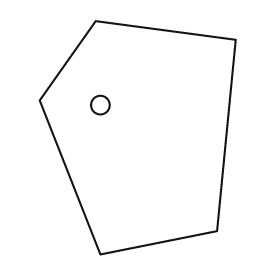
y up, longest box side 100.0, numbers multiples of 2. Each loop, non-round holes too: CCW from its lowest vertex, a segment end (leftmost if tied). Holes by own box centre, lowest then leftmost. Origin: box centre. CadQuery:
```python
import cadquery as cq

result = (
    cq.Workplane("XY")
    .moveTo(-16.0, -50.0)
    .lineTo(34.0, -40.0)
    .lineTo(42.0, 42.0)
    .lineTo(-18.0, 50.0)
    .lineTo(-42.0, 16.0)
    .close()
    .moveTo(-16.0, 14.0)
    .circle(4.0)
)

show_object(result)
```